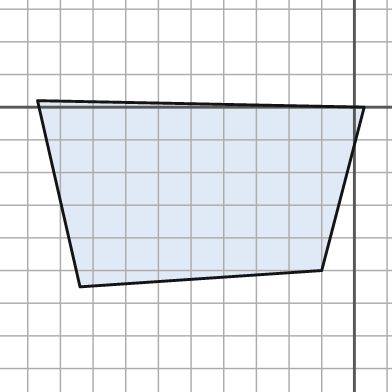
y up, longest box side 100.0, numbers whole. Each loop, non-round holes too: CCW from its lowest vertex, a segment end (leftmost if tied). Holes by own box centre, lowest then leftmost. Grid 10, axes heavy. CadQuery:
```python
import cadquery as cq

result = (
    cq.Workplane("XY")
    .moveTo(-84.0, -55.0)
    .lineTo(-10.0, -50.0)
    .lineTo(3.0, 0.0)
    .lineTo(-97.0, 2.0)
    .close()
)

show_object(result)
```